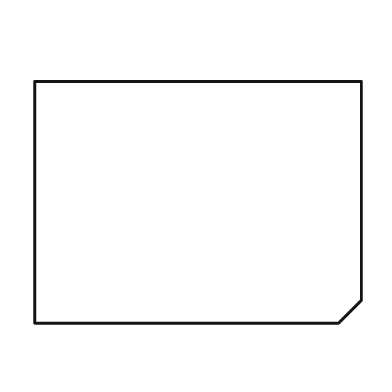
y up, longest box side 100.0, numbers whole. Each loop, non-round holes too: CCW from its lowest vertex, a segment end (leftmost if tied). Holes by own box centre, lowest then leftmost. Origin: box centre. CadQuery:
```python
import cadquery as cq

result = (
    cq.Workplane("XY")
    .moveTo(-50.0, -37.0)
    .lineTo(43.0, -37.0)
    .lineTo(50.0, -30.0)
    .lineTo(50.0, 37.0)
    .lineTo(-50.0, 37.0)
    .close()
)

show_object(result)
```